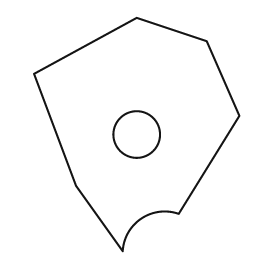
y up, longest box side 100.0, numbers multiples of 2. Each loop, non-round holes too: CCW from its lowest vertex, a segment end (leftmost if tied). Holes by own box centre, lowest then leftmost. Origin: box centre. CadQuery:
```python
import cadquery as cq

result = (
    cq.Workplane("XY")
    .moveTo(-6.0, -50.0)
    .threePointArc((2.0, -36.0), (18.0, -34.0))
    .lineTo(44.0, 8.0)
    .lineTo(30.0, 40.0)
    .lineTo(0.0, 50.0)
    .lineTo(-44.0, 26.0)
    .lineTo(-26.0, -22.0)
    .close()
    .moveTo(0.0, 0.0)
    .circle(10.0)
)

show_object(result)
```